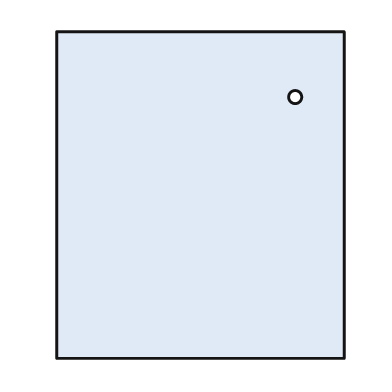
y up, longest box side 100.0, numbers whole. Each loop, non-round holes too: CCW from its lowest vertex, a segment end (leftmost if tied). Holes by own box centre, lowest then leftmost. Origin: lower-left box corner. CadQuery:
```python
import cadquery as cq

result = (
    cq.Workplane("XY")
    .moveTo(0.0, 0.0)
    .lineTo(88.0, 0.0)
    .lineTo(88.0, 100.0)
    .lineTo(0.0, 100.0)
    .close()
    .moveTo(73.0, 80.0)
    .circle(2.0)
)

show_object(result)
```